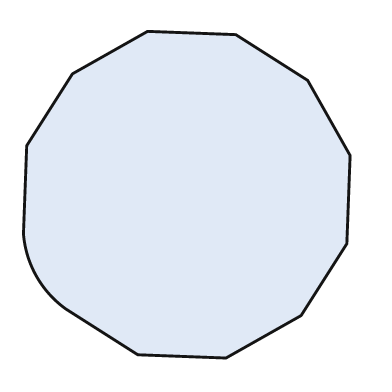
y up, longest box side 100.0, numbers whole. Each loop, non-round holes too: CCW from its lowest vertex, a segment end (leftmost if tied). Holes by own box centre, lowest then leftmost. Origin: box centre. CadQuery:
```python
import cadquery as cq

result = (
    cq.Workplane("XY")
    .moveTo(12.0, -50.0)
    .lineTo(35.0, -37.0)
    .lineTo(49.0, -15.0)
    .lineTo(50.0, 12.0)
    .lineTo(37.0, 35.0)
    .lineTo(15.0, 49.0)
    .lineTo(-12.0, 50.0)
    .lineTo(-35.0, 37.0)
    .lineTo(-49.0, 15.0)
    .lineTo(-50.0, -12.0)
    .threePointArc((-46.0, -25.0), (-37.0, -35.0))
    .lineTo(-15.0, -49.0)
    .close()
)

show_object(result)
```